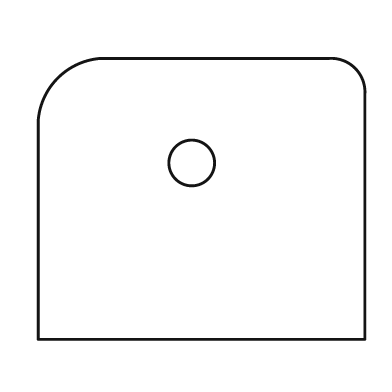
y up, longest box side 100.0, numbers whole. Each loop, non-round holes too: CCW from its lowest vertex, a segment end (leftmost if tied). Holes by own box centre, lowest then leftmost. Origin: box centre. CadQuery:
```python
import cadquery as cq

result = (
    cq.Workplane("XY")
    .moveTo(-50.0, -43.0)
    .lineTo(50.0, -43.0)
    .lineTo(50.0, 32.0)
    .threePointArc((47.0, 40.0), (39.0, 43.0))
    .lineTo(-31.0, 43.0)
    .threePointArc((-44.0, 37.0), (-50.0, 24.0))
    .close()
    .moveTo(-3.0, 11.0)
    .circle(7.0)
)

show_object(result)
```